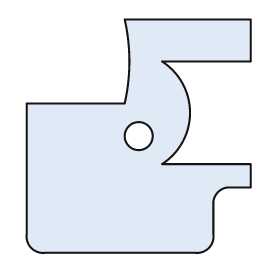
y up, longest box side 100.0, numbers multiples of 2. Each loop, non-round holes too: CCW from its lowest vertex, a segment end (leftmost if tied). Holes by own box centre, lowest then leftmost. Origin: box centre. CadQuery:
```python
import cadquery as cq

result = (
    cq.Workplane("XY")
    .moveTo(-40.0, -50.0)
    .lineTo(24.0, -50.0)
    .threePointArc((30.0, -48.0), (32.0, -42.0))
    .lineTo(32.0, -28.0)
    .threePointArc((34.0, -24.0), (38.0, -22.0))
    .lineTo(48.0, -22.0)
    .lineTo(48.0, -12.0)
    .lineTo(10.0, -12.0)
    .threePointArc((22.0, 10.0), (10.0, 32.0))
    .lineTo(48.0, 32.0)
    .lineTo(48.0, 50.0)
    .lineTo(-6.0, 50.0)
    .threePointArc((-4.0, 32.0), (-6.0, 14.0))
    .lineTo(-48.0, 14.0)
    .lineTo(-48.0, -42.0)
    .threePointArc((-46.0, -48.0), (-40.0, -50.0))
    .close()
    .moveTo(0.0, 0.0)
    .circle(6.0)
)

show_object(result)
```